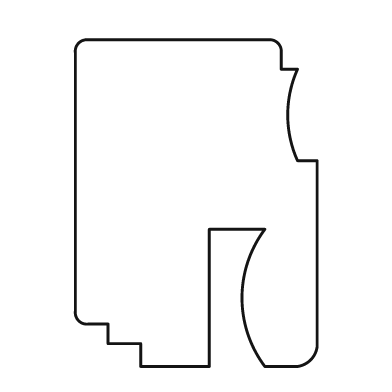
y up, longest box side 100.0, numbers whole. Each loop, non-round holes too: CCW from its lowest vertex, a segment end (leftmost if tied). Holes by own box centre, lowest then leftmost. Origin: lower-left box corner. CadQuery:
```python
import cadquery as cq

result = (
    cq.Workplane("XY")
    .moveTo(20.0, 0.0)
    .lineTo(41.0, 0.0)
    .lineTo(41.0, 42.0)
    .lineTo(58.0, 42.0)
    .threePointArc((51.0, 21.0), (58.0, 0.0))
    .lineTo(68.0, 0.0)
    .threePointArc((72.0, 2.0), (74.0, 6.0))
    .lineTo(74.0, 63.0)
    .lineTo(68.0, 63.0)
    .threePointArc((65.0, 77.0), (68.0, 91.0))
    .lineTo(63.0, 91.0)
    .lineTo(63.0, 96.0)
    .threePointArc((62.0, 99.0), (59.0, 100.0))
    .lineTo(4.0, 100.0)
    .threePointArc((1.0, 99.0), (0.0, 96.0))
    .lineTo(0.0, 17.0)
    .threePointArc((1.0, 14.0), (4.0, 13.0))
    .lineTo(10.0, 13.0)
    .lineTo(10.0, 7.0)
    .lineTo(20.0, 7.0)
    .close()
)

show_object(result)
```